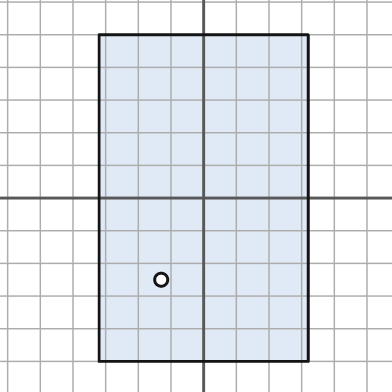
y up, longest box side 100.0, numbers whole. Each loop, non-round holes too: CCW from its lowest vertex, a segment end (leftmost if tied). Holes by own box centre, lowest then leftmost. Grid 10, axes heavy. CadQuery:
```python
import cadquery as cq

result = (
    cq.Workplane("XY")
    .moveTo(-32.0, -50.0)
    .lineTo(32.0, -50.0)
    .lineTo(32.0, 50.0)
    .lineTo(-32.0, 50.0)
    .close()
    .moveTo(-13.0, -25.0)
    .circle(2.0)
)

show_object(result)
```